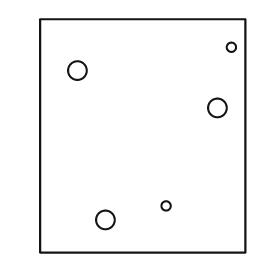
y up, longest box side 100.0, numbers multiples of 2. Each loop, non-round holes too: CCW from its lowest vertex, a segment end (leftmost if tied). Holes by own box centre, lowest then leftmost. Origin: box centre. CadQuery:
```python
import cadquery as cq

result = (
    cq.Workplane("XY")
    .moveTo(-44.0, -50.0)
    .lineTo(44.0, -50.0)
    .lineTo(44.0, 50.0)
    .lineTo(-44.0, 50.0)
    .close()
    .moveTo(-16.0, -36.0)
    .circle(4.0)
    .moveTo(10.0, -30.0)
    .circle(2.0)
    .moveTo(32.0, 12.0)
    .circle(4.0)
    .moveTo(-28.0, 28.0)
    .circle(4.0)
    .moveTo(38.0, 38.0)
    .circle(2.0)
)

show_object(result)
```